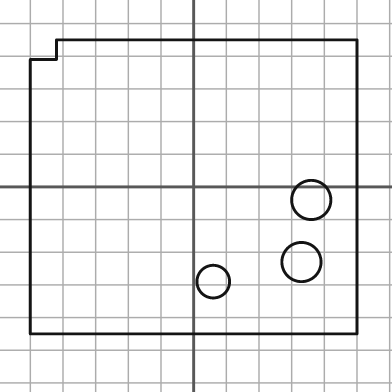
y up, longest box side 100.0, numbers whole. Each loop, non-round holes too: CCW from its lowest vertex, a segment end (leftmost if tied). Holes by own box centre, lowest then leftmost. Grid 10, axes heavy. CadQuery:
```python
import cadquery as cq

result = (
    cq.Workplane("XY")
    .moveTo(-50.0, -45.0)
    .lineTo(50.0, -45.0)
    .lineTo(50.0, 45.0)
    .lineTo(-42.0, 45.0)
    .lineTo(-42.0, 39.0)
    .lineTo(-50.0, 39.0)
    .close()
    .moveTo(6.0, -29.0)
    .circle(5.0)
    .moveTo(33.0, -23.0)
    .circle(6.0)
    .moveTo(36.0, -4.0)
    .circle(6.0)
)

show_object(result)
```